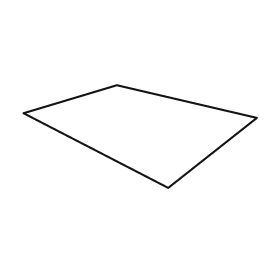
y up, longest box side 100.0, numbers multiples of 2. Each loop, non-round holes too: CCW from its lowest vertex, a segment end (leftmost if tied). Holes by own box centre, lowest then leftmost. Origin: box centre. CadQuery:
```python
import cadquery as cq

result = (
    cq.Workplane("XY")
    .moveTo(12.0, -22.0)
    .lineTo(50.0, 8.0)
    .lineTo(-10.0, 22.0)
    .lineTo(-50.0, 10.0)
    .close()
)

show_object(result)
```